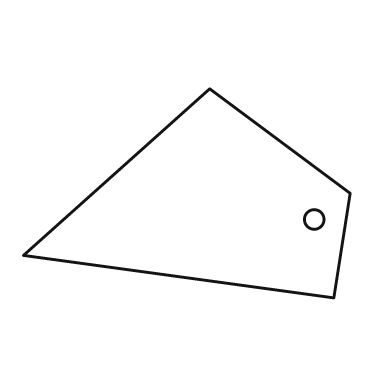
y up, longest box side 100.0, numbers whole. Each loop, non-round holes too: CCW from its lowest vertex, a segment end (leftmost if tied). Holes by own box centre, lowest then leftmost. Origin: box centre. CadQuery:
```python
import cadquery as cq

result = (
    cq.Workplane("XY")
    .moveTo(45.0, -32.0)
    .lineTo(50.0, 0.0)
    .lineTo(7.0, 32.0)
    .lineTo(-50.0, -19.0)
    .close()
    .moveTo(39.0, -8.0)
    .circle(3.0)
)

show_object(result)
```